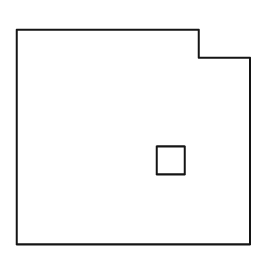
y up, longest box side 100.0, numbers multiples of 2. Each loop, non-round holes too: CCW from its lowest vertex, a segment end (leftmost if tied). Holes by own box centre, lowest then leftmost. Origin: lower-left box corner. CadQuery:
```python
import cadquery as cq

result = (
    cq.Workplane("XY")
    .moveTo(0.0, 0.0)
    .lineTo(100.0, 0.0)
    .lineTo(100.0, 80.0)
    .lineTo(78.0, 80.0)
    .lineTo(78.0, 92.0)
    .lineTo(0.0, 92.0)
    .close()
    .moveTo(60.0, 30.0)
    .lineTo(72.0, 30.0)
    .lineTo(72.0, 42.0)
    .lineTo(60.0, 42.0)
    .close()
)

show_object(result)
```